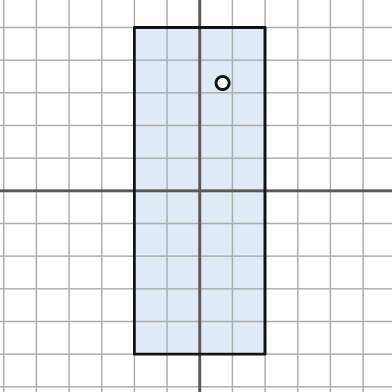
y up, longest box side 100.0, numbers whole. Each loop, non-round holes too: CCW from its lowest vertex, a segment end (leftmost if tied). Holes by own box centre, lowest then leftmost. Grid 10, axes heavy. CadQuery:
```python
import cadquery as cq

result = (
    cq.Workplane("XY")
    .moveTo(-20.0, -50.0)
    .lineTo(20.0, -50.0)
    .lineTo(20.0, 50.0)
    .lineTo(-20.0, 50.0)
    .close()
    .moveTo(7.0, 33.0)
    .circle(2.0)
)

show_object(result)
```